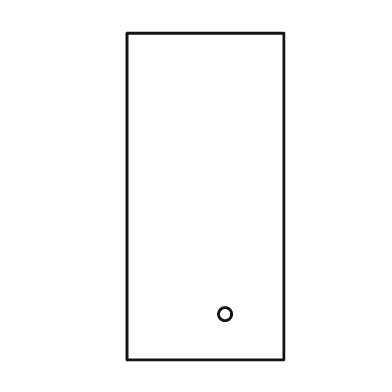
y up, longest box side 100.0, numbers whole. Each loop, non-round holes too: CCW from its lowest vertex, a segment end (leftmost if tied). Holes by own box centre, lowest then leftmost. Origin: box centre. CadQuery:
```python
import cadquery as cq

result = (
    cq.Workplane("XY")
    .moveTo(-24.0, -50.0)
    .lineTo(24.0, -50.0)
    .lineTo(24.0, 50.0)
    .lineTo(-24.0, 50.0)
    .close()
    .moveTo(6.0, -36.0)
    .circle(2.0)
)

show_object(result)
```